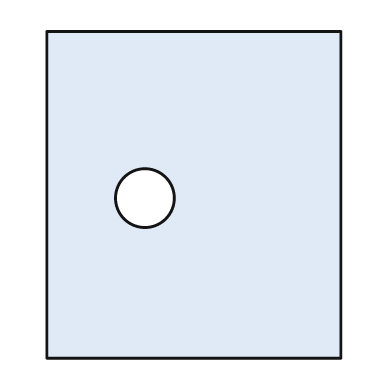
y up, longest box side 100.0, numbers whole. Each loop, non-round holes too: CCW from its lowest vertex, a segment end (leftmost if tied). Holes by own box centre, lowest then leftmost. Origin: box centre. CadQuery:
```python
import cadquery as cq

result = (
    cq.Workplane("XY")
    .moveTo(-45.0, -50.0)
    .lineTo(45.0, -50.0)
    .lineTo(45.0, 50.0)
    .lineTo(-45.0, 50.0)
    .close()
    .moveTo(-15.0, -1.0)
    .circle(9.0)
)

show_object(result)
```